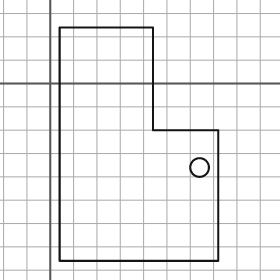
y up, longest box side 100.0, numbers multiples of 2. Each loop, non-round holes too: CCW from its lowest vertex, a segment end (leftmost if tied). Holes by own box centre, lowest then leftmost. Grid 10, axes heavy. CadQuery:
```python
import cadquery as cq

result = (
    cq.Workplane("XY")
    .moveTo(4.0, -76.0)
    .lineTo(72.0, -76.0)
    .lineTo(72.0, -20.0)
    .lineTo(44.0, -20.0)
    .lineTo(44.0, 24.0)
    .lineTo(4.0, 24.0)
    .close()
    .moveTo(64.0, -36.0)
    .circle(4.0)
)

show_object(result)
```